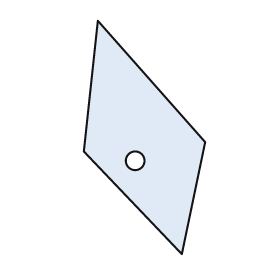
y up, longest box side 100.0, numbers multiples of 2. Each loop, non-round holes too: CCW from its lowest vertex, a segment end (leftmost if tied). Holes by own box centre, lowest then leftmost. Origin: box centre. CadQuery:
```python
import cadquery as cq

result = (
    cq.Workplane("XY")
    .moveTo(16.0, -50.0)
    .lineTo(26.0, -2.0)
    .lineTo(-20.0, 50.0)
    .lineTo(-26.0, -6.0)
    .close()
    .moveTo(-4.0, -10.0)
    .circle(4.0)
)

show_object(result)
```